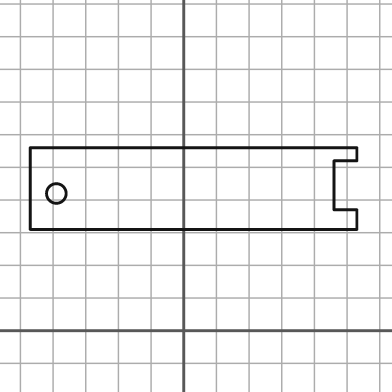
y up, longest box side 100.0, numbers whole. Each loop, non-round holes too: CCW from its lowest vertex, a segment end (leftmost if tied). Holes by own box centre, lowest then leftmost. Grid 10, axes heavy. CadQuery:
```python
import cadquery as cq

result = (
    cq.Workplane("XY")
    .moveTo(-47.0, 31.0)
    .lineTo(53.0, 31.0)
    .lineTo(53.0, 37.0)
    .lineTo(46.0, 37.0)
    .lineTo(46.0, 52.0)
    .lineTo(53.0, 52.0)
    .lineTo(53.0, 56.0)
    .lineTo(-47.0, 56.0)
    .close()
    .moveTo(-39.0, 42.0)
    .circle(3.0)
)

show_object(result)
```